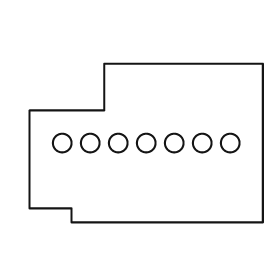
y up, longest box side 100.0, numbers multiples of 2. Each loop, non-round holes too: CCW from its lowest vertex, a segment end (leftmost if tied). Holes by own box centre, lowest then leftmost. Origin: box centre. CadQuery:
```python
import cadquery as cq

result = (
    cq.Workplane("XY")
    .moveTo(-32.0, -34.0)
    .lineTo(50.0, -34.0)
    .lineTo(50.0, 34.0)
    .lineTo(-18.0, 34.0)
    .lineTo(-18.0, 14.0)
    .lineTo(-50.0, 14.0)
    .lineTo(-50.0, -28.0)
    .lineTo(-32.0, -28.0)
    .close()
    .moveTo(-36.0, 0.0)
    .circle(4.0)
    .moveTo(-24.0, 0.0)
    .circle(4.0)
    .moveTo(-12.0, 0.0)
    .circle(4.0)
    .moveTo(0.0, 0.0)
    .circle(4.0)
    .moveTo(12.0, 0.0)
    .circle(4.0)
    .moveTo(24.0, 0.0)
    .circle(4.0)
    .moveTo(36.0, 0.0)
    .circle(4.0)
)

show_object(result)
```